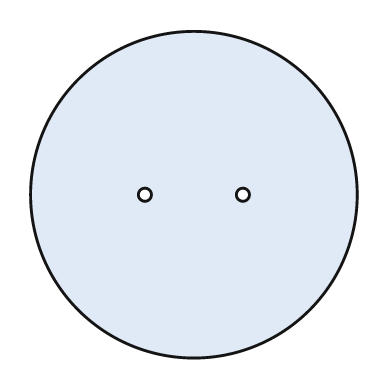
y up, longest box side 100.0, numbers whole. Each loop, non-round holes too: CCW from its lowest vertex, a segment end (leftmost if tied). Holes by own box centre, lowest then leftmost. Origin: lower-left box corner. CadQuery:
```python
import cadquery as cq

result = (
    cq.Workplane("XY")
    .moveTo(50.0, 50.0)
    .circle(50.0)
    .moveTo(35.0, 50.0)
    .circle(2.0)
    .moveTo(65.0, 50.0)
    .circle(2.0)
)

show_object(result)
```